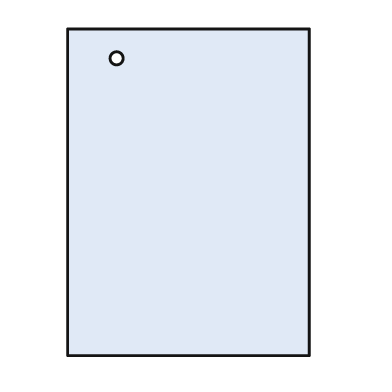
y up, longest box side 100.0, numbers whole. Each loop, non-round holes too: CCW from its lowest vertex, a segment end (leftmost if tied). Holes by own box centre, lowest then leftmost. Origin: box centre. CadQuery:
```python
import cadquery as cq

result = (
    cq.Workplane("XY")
    .moveTo(-37.0, -50.0)
    .lineTo(37.0, -50.0)
    .lineTo(37.0, 50.0)
    .lineTo(-37.0, 50.0)
    .close()
    .moveTo(-22.0, 41.0)
    .circle(2.0)
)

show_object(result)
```